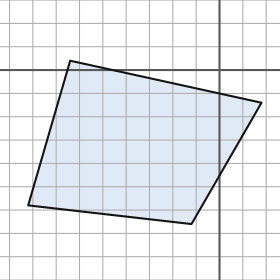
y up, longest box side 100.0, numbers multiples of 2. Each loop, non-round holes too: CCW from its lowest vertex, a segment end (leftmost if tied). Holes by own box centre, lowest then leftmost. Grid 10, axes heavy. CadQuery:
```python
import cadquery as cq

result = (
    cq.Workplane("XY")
    .moveTo(-12.0, -66.0)
    .lineTo(18.0, -14.0)
    .lineTo(-64.0, 4.0)
    .lineTo(-82.0, -58.0)
    .close()
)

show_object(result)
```